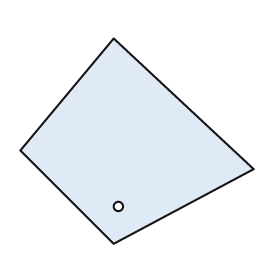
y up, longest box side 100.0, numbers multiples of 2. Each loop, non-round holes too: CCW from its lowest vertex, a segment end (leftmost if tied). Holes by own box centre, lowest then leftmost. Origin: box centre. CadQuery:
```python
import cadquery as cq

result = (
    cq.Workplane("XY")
    .moveTo(-10.0, -44.0)
    .lineTo(50.0, -12.0)
    .lineTo(-10.0, 44.0)
    .lineTo(-50.0, -4.0)
    .close()
    .moveTo(-8.0, -28.0)
    .circle(2.0)
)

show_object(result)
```